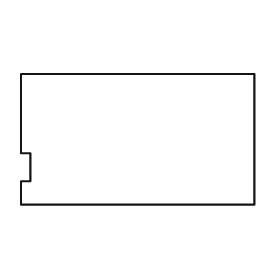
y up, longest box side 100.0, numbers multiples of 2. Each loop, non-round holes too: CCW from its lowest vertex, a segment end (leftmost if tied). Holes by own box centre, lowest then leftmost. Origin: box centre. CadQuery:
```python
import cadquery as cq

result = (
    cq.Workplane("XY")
    .moveTo(-50.0, -28.0)
    .lineTo(50.0, -28.0)
    .lineTo(50.0, 28.0)
    .lineTo(-50.0, 28.0)
    .lineTo(-50.0, -6.0)
    .lineTo(-46.0, -6.0)
    .lineTo(-46.0, -18.0)
    .lineTo(-50.0, -18.0)
    .close()
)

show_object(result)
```